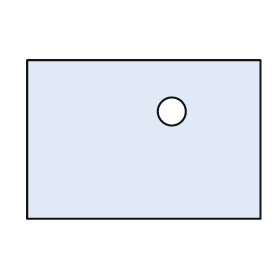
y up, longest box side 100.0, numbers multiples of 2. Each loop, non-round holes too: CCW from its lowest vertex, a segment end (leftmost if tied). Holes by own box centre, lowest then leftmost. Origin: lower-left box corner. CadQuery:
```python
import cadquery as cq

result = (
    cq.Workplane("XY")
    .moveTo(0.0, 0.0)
    .lineTo(100.0, 0.0)
    .lineTo(100.0, 68.0)
    .lineTo(0.0, 68.0)
    .close()
    .moveTo(62.0, 46.0)
    .circle(6.0)
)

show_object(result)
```